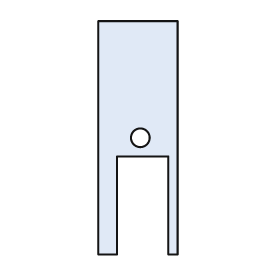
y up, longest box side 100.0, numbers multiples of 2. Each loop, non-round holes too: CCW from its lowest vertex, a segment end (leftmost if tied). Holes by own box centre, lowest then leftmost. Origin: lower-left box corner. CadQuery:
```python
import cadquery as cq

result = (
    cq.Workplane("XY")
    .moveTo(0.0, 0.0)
    .lineTo(8.0, 0.0)
    .lineTo(8.0, 42.0)
    .lineTo(30.0, 42.0)
    .lineTo(30.0, 0.0)
    .lineTo(34.0, 0.0)
    .lineTo(34.0, 100.0)
    .lineTo(0.0, 100.0)
    .close()
    .moveTo(18.0, 50.0)
    .circle(4.0)
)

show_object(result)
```